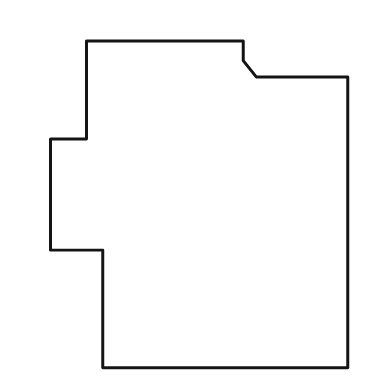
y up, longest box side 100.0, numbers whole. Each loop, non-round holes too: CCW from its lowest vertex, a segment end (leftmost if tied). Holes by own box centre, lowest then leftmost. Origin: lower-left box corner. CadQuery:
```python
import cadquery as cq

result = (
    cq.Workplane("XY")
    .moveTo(16.0, 0.0)
    .lineTo(91.0, 0.0)
    .lineTo(91.0, 89.0)
    .lineTo(63.0, 89.0)
    .lineTo(59.0, 94.0)
    .lineTo(59.0, 100.0)
    .lineTo(11.0, 100.0)
    .lineTo(11.0, 70.0)
    .lineTo(0.0, 70.0)
    .lineTo(0.0, 36.0)
    .lineTo(16.0, 36.0)
    .close()
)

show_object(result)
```